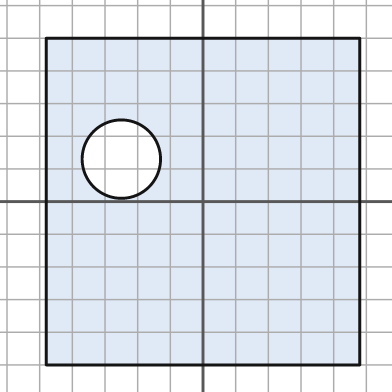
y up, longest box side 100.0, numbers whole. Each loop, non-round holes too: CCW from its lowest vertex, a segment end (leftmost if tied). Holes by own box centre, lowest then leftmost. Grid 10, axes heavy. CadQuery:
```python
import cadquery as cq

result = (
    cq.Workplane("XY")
    .moveTo(-48.0, -50.0)
    .lineTo(48.0, -50.0)
    .lineTo(48.0, 50.0)
    .lineTo(-48.0, 50.0)
    .close()
    .moveTo(-25.0, 13.0)
    .circle(12.0)
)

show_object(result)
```